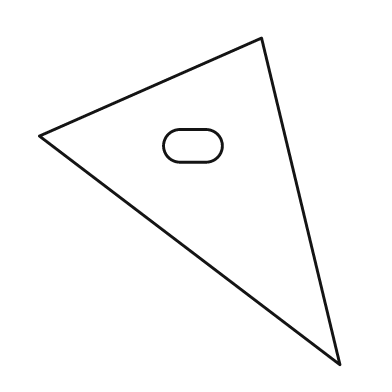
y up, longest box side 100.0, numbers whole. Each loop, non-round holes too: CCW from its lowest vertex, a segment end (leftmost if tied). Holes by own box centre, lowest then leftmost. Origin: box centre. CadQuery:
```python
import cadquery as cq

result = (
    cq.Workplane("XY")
    .moveTo(46.0, -50.0)
    .lineTo(22.0, 50.0)
    .lineTo(-46.0, 20.0)
    .close()
    .moveTo(-3.0, 12.0)
    .lineTo(5.0, 12.0)
    .threePointArc((10.0, 17.0), (5.0, 22.0))
    .lineTo(-3.0, 22.0)
    .threePointArc((-8.0, 17.0), (-3.0, 12.0))
    .close()
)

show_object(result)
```